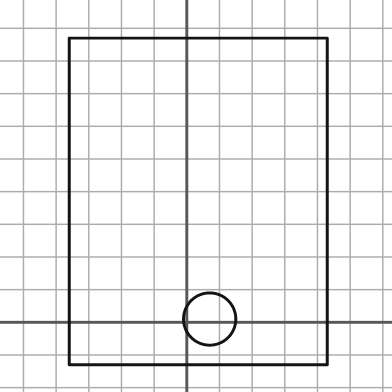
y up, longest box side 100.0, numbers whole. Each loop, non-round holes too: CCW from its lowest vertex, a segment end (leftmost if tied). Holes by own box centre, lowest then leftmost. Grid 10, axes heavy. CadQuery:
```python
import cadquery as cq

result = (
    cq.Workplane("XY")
    .moveTo(-36.0, -13.0)
    .lineTo(43.0, -13.0)
    .lineTo(43.0, 87.0)
    .lineTo(-36.0, 87.0)
    .close()
    .moveTo(7.0, 1.0)
    .circle(8.0)
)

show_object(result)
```